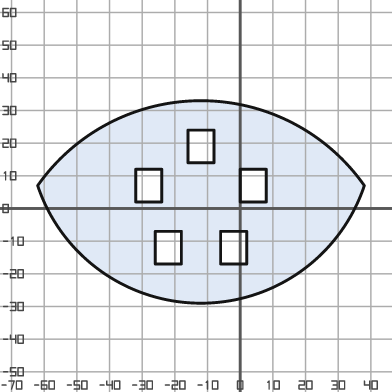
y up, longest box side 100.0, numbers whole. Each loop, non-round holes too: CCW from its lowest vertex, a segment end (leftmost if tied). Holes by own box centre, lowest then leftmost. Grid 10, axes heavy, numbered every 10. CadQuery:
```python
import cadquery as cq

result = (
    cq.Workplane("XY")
    .moveTo(-62.0, 7.0)
    .threePointArc((-12.0, -29.0), (38.0, 7.0))
    .threePointArc((-12.0, 33.0), (-62.0, 7.0))
    .close()
    .moveTo(-26.0, -17.0)
    .lineTo(-18.0, -17.0)
    .lineTo(-18.0, -7.0)
    .lineTo(-26.0, -7.0)
    .close()
    .moveTo(-6.0, -17.0)
    .lineTo(2.0, -17.0)
    .lineTo(2.0, -7.0)
    .lineTo(-6.0, -7.0)
    .close()
    .moveTo(-32.0, 2.0)
    .lineTo(-24.0, 2.0)
    .lineTo(-24.0, 12.0)
    .lineTo(-32.0, 12.0)
    .close()
    .moveTo(0.0, 2.0)
    .lineTo(8.0, 2.0)
    .lineTo(8.0, 12.0)
    .lineTo(0.0, 12.0)
    .close()
    .moveTo(-16.0, 14.0)
    .lineTo(-8.0, 14.0)
    .lineTo(-8.0, 24.0)
    .lineTo(-16.0, 24.0)
    .close()
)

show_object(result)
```